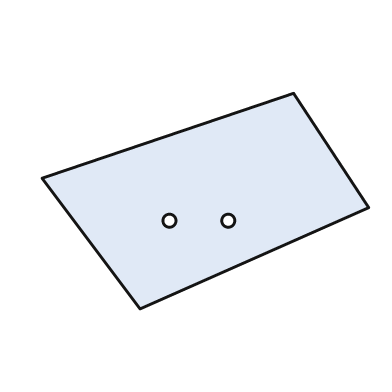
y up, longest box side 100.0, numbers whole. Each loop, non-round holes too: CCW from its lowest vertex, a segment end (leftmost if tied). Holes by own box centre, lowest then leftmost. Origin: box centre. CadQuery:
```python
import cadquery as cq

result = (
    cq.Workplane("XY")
    .moveTo(-20.0, -33.0)
    .lineTo(50.0, -2.0)
    .lineTo(27.0, 33.0)
    .lineTo(-50.0, 7.0)
    .close()
    .moveTo(-11.0, -6.0)
    .circle(2.0)
    .moveTo(7.0, -6.0)
    .circle(2.0)
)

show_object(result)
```